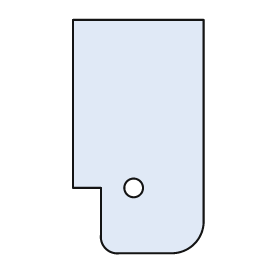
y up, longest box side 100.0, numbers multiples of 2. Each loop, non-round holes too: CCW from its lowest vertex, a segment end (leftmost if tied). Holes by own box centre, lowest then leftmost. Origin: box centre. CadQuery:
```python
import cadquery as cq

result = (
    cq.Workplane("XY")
    .moveTo(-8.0, -50.0)
    .lineTo(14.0, -50.0)
    .threePointArc((24.0, -46.0), (28.0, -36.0))
    .lineTo(28.0, 50.0)
    .lineTo(-28.0, 50.0)
    .lineTo(-28.0, -22.0)
    .lineTo(-16.0, -22.0)
    .lineTo(-16.0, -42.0)
    .threePointArc((-14.0, -48.0), (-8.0, -50.0))
    .close()
    .moveTo(-2.0, -22.0)
    .circle(4.0)
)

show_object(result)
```